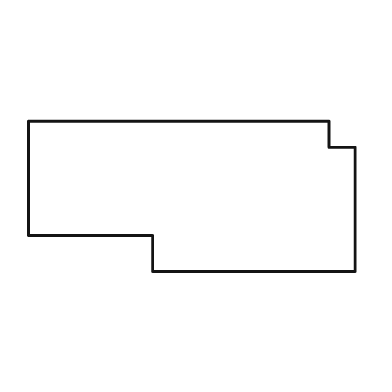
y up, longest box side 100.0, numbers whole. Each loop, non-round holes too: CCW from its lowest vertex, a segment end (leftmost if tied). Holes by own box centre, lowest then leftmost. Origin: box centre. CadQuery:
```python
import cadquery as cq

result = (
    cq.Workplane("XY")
    .moveTo(-12.0, -23.0)
    .lineTo(50.0, -23.0)
    .lineTo(50.0, 15.0)
    .lineTo(42.0, 15.0)
    .lineTo(42.0, 23.0)
    .lineTo(-50.0, 23.0)
    .lineTo(-50.0, -12.0)
    .lineTo(-12.0, -12.0)
    .close()
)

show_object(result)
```